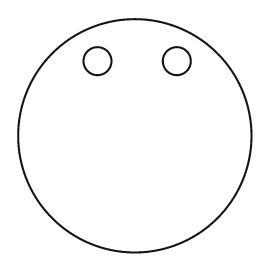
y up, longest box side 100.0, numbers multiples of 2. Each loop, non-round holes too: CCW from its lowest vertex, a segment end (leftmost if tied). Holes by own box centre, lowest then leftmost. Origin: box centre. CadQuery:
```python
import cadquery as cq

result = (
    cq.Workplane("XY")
    .moveTo(0.0, 0.0)
    .circle(50.0)
    .moveTo(-16.0, 32.0)
    .circle(6.0)
    .moveTo(18.0, 32.0)
    .circle(6.0)
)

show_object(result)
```